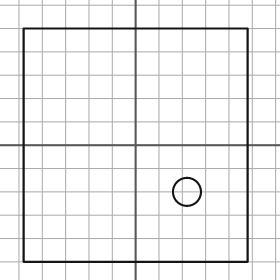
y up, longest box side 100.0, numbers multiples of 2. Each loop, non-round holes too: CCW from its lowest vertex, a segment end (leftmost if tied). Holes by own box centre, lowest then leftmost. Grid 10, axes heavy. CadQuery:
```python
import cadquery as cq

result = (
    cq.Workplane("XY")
    .moveTo(-48.0, -50.0)
    .lineTo(48.0, -50.0)
    .lineTo(48.0, 50.0)
    .lineTo(-48.0, 50.0)
    .close()
    .moveTo(22.0, -20.0)
    .circle(6.0)
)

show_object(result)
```